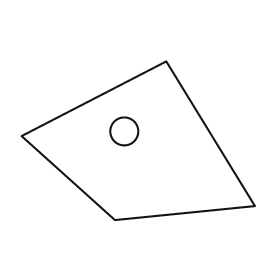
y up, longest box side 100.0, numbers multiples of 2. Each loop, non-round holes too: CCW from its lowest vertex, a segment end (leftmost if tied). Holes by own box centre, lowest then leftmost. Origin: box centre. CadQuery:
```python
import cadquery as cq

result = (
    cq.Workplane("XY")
    .moveTo(-10.0, -34.0)
    .lineTo(50.0, -28.0)
    .lineTo(12.0, 34.0)
    .lineTo(-50.0, 2.0)
    .close()
    .moveTo(-6.0, 4.0)
    .circle(6.0)
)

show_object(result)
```